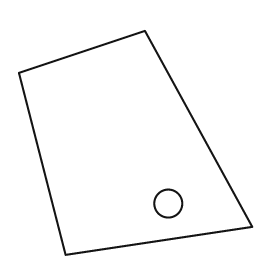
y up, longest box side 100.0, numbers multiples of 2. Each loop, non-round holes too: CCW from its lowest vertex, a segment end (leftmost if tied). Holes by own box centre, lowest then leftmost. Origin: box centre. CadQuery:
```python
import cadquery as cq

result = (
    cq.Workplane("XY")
    .moveTo(-30.0, -48.0)
    .lineTo(50.0, -36.0)
    .lineTo(4.0, 48.0)
    .lineTo(-50.0, 30.0)
    .close()
    .moveTo(14.0, -26.0)
    .circle(6.0)
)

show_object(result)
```